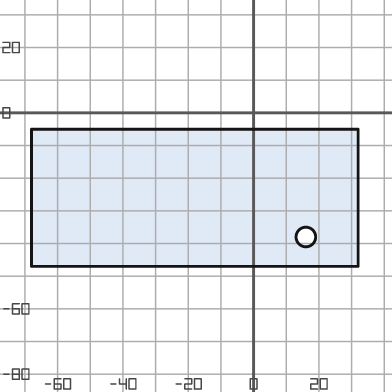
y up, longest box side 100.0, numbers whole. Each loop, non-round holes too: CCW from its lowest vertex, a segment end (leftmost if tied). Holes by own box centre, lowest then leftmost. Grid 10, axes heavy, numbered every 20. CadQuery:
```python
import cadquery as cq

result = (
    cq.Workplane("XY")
    .moveTo(-68.0, -47.0)
    .lineTo(32.0, -47.0)
    .lineTo(32.0, -5.0)
    .lineTo(-68.0, -5.0)
    .close()
    .moveTo(16.0, -38.0)
    .circle(3.0)
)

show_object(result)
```